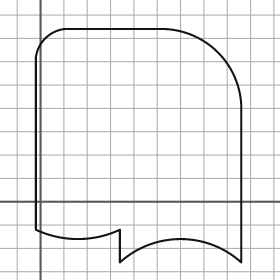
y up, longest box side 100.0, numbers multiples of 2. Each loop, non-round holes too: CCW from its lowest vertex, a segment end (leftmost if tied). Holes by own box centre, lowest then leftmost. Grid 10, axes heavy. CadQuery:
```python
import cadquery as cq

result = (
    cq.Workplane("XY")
    .moveTo(34.0, -26.0)
    .threePointArc((60.0, -16.0), (86.0, -26.0))
    .lineTo(86.0, 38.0)
    .threePointArc((76.0, 64.0), (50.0, 74.0))
    .lineTo(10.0, 74.0)
    .threePointArc((2.0, 70.0), (-2.0, 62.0))
    .lineTo(-2.0, -12.0)
    .threePointArc((16.0, -16.0), (34.0, -12.0))
    .close()
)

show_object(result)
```